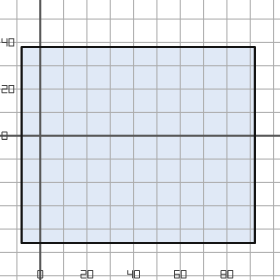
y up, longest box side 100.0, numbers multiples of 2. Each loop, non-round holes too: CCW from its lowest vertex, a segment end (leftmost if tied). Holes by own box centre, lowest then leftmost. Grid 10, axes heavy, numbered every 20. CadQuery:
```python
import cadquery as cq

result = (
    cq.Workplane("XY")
    .moveTo(-8.0, -46.0)
    .lineTo(92.0, -46.0)
    .lineTo(92.0, 38.0)
    .lineTo(-8.0, 38.0)
    .close()
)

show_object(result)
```